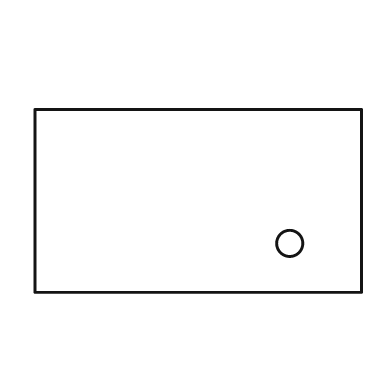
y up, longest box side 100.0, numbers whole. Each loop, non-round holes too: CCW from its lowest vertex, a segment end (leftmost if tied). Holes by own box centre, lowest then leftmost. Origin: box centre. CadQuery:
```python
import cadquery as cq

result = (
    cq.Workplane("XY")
    .moveTo(-50.0, -28.0)
    .lineTo(50.0, -28.0)
    .lineTo(50.0, 28.0)
    .lineTo(-50.0, 28.0)
    .close()
    .moveTo(28.0, -13.0)
    .circle(4.0)
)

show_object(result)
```